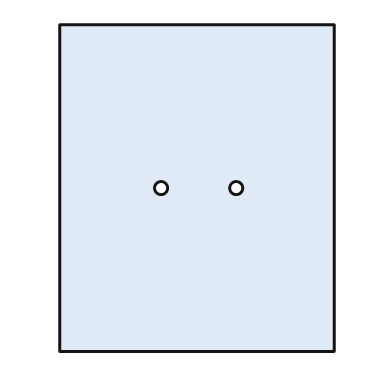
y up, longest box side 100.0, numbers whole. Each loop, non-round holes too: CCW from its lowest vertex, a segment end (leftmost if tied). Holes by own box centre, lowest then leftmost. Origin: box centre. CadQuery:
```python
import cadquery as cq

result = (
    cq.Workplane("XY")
    .moveTo(-42.0, -50.0)
    .lineTo(42.0, -50.0)
    .lineTo(42.0, 50.0)
    .lineTo(-42.0, 50.0)
    .close()
    .moveTo(-11.0, 0.0)
    .circle(2.0)
    .moveTo(12.0, 0.0)
    .circle(2.0)
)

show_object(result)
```